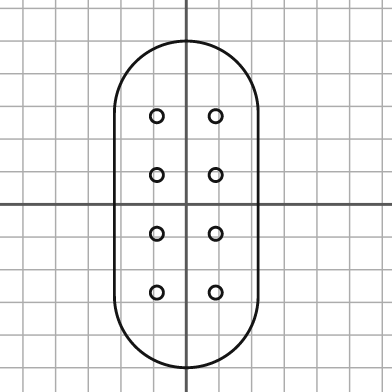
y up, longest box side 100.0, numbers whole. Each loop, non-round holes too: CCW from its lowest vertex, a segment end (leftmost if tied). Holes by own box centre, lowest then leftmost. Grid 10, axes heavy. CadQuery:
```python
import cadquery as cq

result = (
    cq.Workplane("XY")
    .moveTo(-22.0, -28.0)
    .threePointArc((0.0, -50.0), (22.0, -28.0))
    .lineTo(22.0, 28.0)
    .threePointArc((0.0, 50.0), (-22.0, 28.0))
    .close()
    .moveTo(-9.0, -27.0)
    .circle(2.0)
    .moveTo(9.0, -27.0)
    .circle(2.0)
    .moveTo(-9.0, -9.0)
    .circle(2.0)
    .moveTo(9.0, -9.0)
    .circle(2.0)
    .moveTo(-9.0, 9.0)
    .circle(2.0)
    .moveTo(9.0, 9.0)
    .circle(2.0)
    .moveTo(-9.0, 27.0)
    .circle(2.0)
    .moveTo(9.0, 27.0)
    .circle(2.0)
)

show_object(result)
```